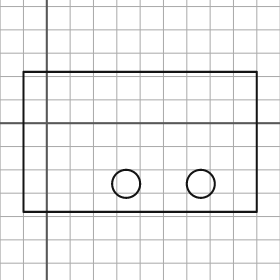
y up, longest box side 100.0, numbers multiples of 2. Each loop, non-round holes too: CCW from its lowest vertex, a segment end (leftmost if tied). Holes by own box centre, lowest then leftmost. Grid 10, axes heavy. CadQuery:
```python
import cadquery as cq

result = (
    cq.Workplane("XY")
    .moveTo(-10.0, -38.0)
    .lineTo(90.0, -38.0)
    .lineTo(90.0, 22.0)
    .lineTo(-10.0, 22.0)
    .close()
    .moveTo(34.0, -26.0)
    .circle(6.0)
    .moveTo(66.0, -26.0)
    .circle(6.0)
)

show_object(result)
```